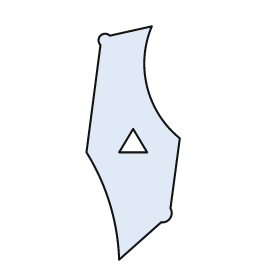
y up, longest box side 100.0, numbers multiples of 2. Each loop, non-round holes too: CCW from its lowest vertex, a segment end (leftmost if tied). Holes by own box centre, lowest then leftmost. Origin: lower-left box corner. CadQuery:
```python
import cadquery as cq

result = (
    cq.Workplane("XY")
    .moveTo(14.0, 0.0)
    .lineTo(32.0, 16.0)
    .threePointArc((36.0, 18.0), (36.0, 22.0))
    .lineTo(40.0, 52.0)
    .threePointArc((26.0, 74.0), (28.0, 100.0))
    .lineTo(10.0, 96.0)
    .threePointArc((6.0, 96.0), (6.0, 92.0))
    .lineTo(0.0, 46.0)
    .threePointArc((10.0, 24.0), (14.0, 0.0))
    .close()
    .moveTo(14.0, 46.0)
    .lineTo(26.0, 46.0)
    .lineTo(20.0, 56.0)
    .close()
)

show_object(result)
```